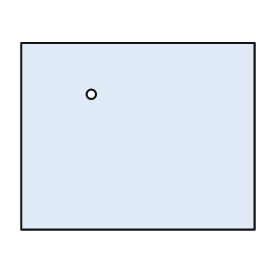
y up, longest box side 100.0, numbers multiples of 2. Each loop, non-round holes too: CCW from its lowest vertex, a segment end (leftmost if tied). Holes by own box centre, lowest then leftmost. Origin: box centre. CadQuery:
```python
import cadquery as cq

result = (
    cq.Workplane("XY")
    .moveTo(-50.0, -40.0)
    .lineTo(50.0, -40.0)
    .lineTo(50.0, 40.0)
    .lineTo(-50.0, 40.0)
    .close()
    .moveTo(-20.0, 18.0)
    .circle(2.0)
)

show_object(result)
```